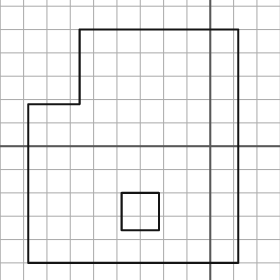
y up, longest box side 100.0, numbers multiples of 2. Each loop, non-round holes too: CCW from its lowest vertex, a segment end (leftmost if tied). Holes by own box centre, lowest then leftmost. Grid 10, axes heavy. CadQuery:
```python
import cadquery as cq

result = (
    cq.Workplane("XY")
    .moveTo(-78.0, -50.0)
    .lineTo(12.0, -50.0)
    .lineTo(12.0, 50.0)
    .lineTo(-56.0, 50.0)
    .lineTo(-56.0, 18.0)
    .lineTo(-78.0, 18.0)
    .close()
    .moveTo(-38.0, -36.0)
    .lineTo(-22.0, -36.0)
    .lineTo(-22.0, -20.0)
    .lineTo(-38.0, -20.0)
    .close()
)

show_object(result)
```